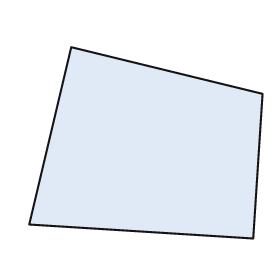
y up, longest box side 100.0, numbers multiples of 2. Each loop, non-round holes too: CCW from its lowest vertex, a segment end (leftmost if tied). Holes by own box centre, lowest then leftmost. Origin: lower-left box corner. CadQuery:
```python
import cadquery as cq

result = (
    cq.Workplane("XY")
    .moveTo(96.0, 0.0)
    .lineTo(100.0, 62.0)
    .lineTo(18.0, 82.0)
    .lineTo(0.0, 6.0)
    .close()
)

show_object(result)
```